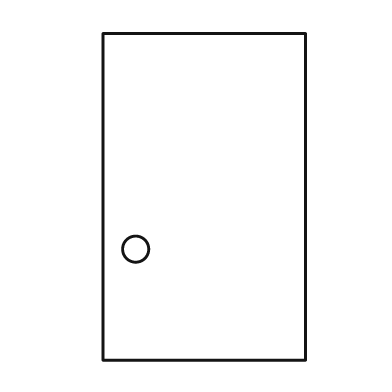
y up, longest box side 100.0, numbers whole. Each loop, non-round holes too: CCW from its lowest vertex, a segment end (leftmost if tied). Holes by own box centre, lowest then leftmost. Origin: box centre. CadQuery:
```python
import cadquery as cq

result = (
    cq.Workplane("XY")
    .moveTo(-31.0, -50.0)
    .lineTo(31.0, -50.0)
    .lineTo(31.0, 50.0)
    .lineTo(-31.0, 50.0)
    .close()
    .moveTo(-21.0, -16.0)
    .circle(4.0)
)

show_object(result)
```